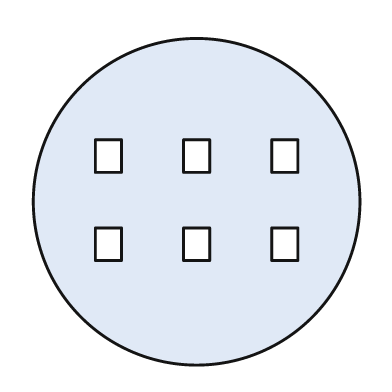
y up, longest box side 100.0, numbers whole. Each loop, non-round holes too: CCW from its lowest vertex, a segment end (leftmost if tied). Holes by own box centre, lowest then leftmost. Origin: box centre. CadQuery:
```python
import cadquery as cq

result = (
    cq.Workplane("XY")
    .moveTo(0.0, 0.0)
    .circle(50.0)
    .moveTo(-31.0, -18.0)
    .lineTo(-23.0, -18.0)
    .lineTo(-23.0, -8.0)
    .lineTo(-31.0, -8.0)
    .close()
    .moveTo(-4.0, -18.0)
    .lineTo(4.0, -18.0)
    .lineTo(4.0, -8.0)
    .lineTo(-4.0, -8.0)
    .close()
    .moveTo(23.0, -18.0)
    .lineTo(31.0, -18.0)
    .lineTo(31.0, -8.0)
    .lineTo(23.0, -8.0)
    .close()
    .moveTo(-31.0, 9.0)
    .lineTo(-23.0, 9.0)
    .lineTo(-23.0, 19.0)
    .lineTo(-31.0, 19.0)
    .close()
    .moveTo(-4.0, 9.0)
    .lineTo(4.0, 9.0)
    .lineTo(4.0, 19.0)
    .lineTo(-4.0, 19.0)
    .close()
    .moveTo(23.0, 9.0)
    .lineTo(31.0, 9.0)
    .lineTo(31.0, 19.0)
    .lineTo(23.0, 19.0)
    .close()
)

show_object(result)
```